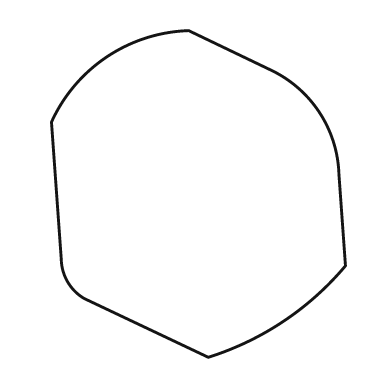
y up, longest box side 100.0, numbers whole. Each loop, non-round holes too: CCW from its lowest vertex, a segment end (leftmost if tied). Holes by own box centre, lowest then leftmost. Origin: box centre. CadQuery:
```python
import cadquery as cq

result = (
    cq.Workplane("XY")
    .moveTo(3.0, -50.0)
    .threePointArc((26.0, -39.0), (45.0, -22.0))
    .lineTo(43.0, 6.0)
    .threePointArc((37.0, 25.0), (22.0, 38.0))
    .lineTo(-3.0, 50.0)
    .threePointArc((-28.0, 42.0), (-45.0, 22.0))
    .lineTo(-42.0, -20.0)
    .threePointArc((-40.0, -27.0), (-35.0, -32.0))
    .close()
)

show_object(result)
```